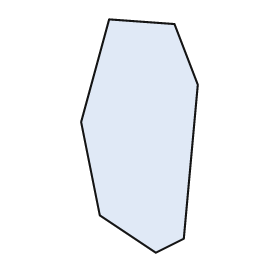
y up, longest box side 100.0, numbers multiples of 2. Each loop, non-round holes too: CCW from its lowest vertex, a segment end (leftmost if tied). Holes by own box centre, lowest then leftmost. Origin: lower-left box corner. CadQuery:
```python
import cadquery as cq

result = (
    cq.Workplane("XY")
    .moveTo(32.0, 0.0)
    .lineTo(44.0, 6.0)
    .lineTo(50.0, 72.0)
    .lineTo(40.0, 98.0)
    .lineTo(12.0, 100.0)
    .lineTo(0.0, 56.0)
    .lineTo(8.0, 16.0)
    .close()
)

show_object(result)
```